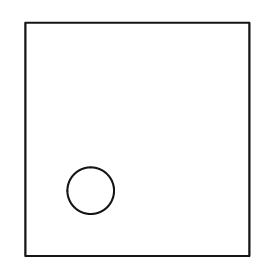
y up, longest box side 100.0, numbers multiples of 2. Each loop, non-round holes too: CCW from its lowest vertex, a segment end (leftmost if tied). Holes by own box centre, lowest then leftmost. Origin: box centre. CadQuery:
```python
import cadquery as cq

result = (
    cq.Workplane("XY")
    .moveTo(-48.0, -50.0)
    .lineTo(48.0, -50.0)
    .lineTo(48.0, 50.0)
    .lineTo(-48.0, 50.0)
    .close()
    .moveTo(-20.0, -22.0)
    .circle(10.0)
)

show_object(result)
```